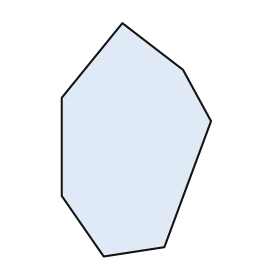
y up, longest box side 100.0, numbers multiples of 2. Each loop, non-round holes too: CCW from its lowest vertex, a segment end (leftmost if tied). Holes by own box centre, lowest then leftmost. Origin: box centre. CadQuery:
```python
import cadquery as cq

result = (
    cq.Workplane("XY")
    .moveTo(-14.0, -50.0)
    .lineTo(12.0, -46.0)
    .lineTo(32.0, 8.0)
    .lineTo(20.0, 30.0)
    .lineTo(-6.0, 50.0)
    .lineTo(-32.0, 18.0)
    .lineTo(-32.0, -24.0)
    .close()
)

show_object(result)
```